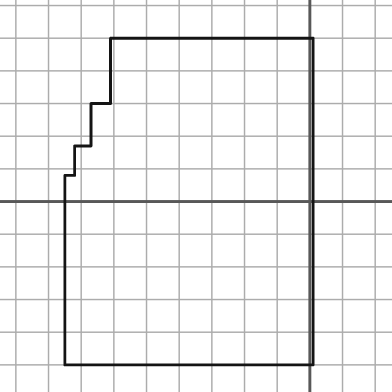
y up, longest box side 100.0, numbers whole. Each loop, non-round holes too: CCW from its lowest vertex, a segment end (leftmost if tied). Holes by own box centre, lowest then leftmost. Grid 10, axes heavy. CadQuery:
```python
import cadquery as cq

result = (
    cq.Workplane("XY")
    .moveTo(-75.0, -50.0)
    .lineTo(1.0, -50.0)
    .lineTo(1.0, 50.0)
    .lineTo(-61.0, 50.0)
    .lineTo(-61.0, 30.0)
    .lineTo(-67.0, 30.0)
    .lineTo(-67.0, 17.0)
    .lineTo(-72.0, 17.0)
    .lineTo(-72.0, 8.0)
    .lineTo(-75.0, 8.0)
    .close()
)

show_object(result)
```